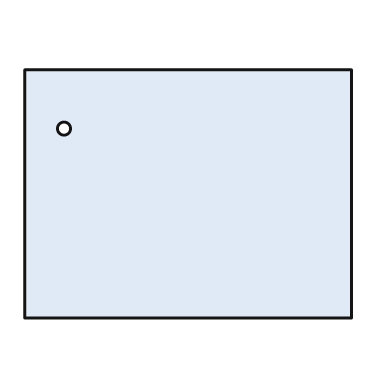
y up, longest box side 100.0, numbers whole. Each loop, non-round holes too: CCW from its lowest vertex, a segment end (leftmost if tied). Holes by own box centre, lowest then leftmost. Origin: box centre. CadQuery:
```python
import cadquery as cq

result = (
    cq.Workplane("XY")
    .moveTo(-50.0, -38.0)
    .lineTo(50.0, -38.0)
    .lineTo(50.0, 38.0)
    .lineTo(-50.0, 38.0)
    .close()
    .moveTo(-38.0, 20.0)
    .circle(2.0)
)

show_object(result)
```